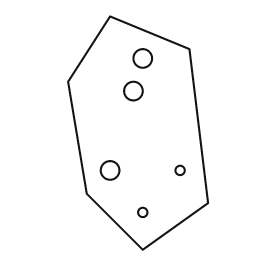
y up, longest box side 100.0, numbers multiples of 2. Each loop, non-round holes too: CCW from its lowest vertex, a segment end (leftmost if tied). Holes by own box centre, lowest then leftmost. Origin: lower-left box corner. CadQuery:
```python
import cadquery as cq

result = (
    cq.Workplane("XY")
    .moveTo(32.0, 0.0)
    .lineTo(60.0, 20.0)
    .lineTo(52.0, 86.0)
    .lineTo(18.0, 100.0)
    .lineTo(0.0, 72.0)
    .lineTo(8.0, 24.0)
    .close()
    .moveTo(32.0, 16.0)
    .circle(2.0)
    .moveTo(18.0, 34.0)
    .circle(4.0)
    .moveTo(48.0, 34.0)
    .circle(2.0)
    .moveTo(28.0, 68.0)
    .circle(4.0)
    .moveTo(32.0, 82.0)
    .circle(4.0)
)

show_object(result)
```